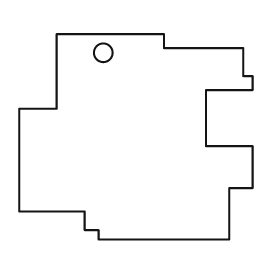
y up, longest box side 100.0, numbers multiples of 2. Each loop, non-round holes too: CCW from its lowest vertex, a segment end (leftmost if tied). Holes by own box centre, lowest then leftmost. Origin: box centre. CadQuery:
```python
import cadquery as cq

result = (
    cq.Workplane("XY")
    .moveTo(-16.0, -44.0)
    .lineTo(40.0, -44.0)
    .lineTo(40.0, -22.0)
    .lineTo(50.0, -22.0)
    .lineTo(50.0, -4.0)
    .lineTo(30.0, -4.0)
    .lineTo(30.0, 20.0)
    .lineTo(50.0, 20.0)
    .lineTo(50.0, 26.0)
    .lineTo(46.0, 26.0)
    .lineTo(46.0, 38.0)
    .lineTo(12.0, 38.0)
    .lineTo(12.0, 44.0)
    .lineTo(-34.0, 44.0)
    .lineTo(-34.0, 12.0)
    .lineTo(-50.0, 12.0)
    .lineTo(-50.0, -32.0)
    .lineTo(-22.0, -32.0)
    .lineTo(-22.0, -40.0)
    .lineTo(-16.0, -40.0)
    .close()
    .moveTo(-14.0, 36.0)
    .circle(4.0)
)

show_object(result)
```